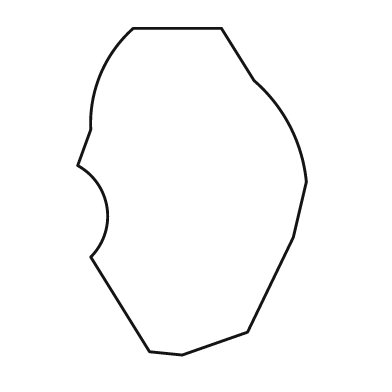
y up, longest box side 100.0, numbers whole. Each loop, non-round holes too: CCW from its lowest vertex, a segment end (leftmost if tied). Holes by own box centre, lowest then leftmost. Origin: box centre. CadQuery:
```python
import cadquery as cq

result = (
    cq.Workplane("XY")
    .moveTo(-3.0, -50.0)
    .lineTo(17.0, -43.0)
    .lineTo(31.0, -14.0)
    .lineTo(35.0, 3.0)
    .threePointArc((30.0, 20.0), (19.0, 34.0))
    .lineTo(9.0, 50.0)
    .lineTo(-18.0, 50.0)
    .threePointArc((-28.0, 36.0), (-31.0, 19.0))
    .lineTo(-35.0, 8.0)
    .threePointArc((-26.0, -5.0), (-31.0, -20.0))
    .lineTo(-13.0, -49.0)
    .close()
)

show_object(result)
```